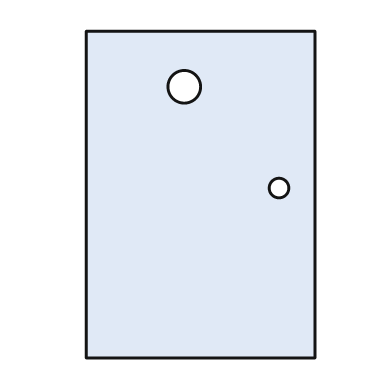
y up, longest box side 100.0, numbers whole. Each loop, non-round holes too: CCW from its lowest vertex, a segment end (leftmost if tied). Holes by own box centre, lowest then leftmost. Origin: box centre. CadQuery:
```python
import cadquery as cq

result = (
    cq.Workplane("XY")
    .moveTo(-35.0, -50.0)
    .lineTo(35.0, -50.0)
    .lineTo(35.0, 50.0)
    .lineTo(-35.0, 50.0)
    .close()
    .moveTo(24.0, 2.0)
    .circle(3.0)
    .moveTo(-5.0, 33.0)
    .circle(5.0)
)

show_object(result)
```